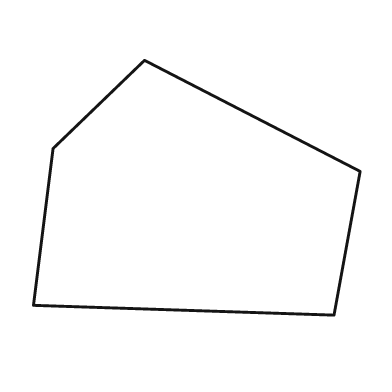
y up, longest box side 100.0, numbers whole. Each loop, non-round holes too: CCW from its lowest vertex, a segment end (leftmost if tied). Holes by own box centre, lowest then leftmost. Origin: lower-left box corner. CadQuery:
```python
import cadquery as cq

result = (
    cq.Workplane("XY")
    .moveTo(92.0, 0.0)
    .lineTo(100.0, 44.0)
    .lineTo(34.0, 78.0)
    .lineTo(6.0, 51.0)
    .lineTo(0.0, 3.0)
    .close()
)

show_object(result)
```